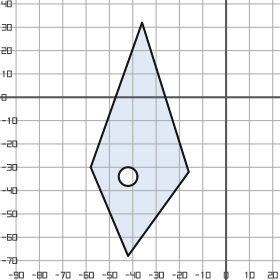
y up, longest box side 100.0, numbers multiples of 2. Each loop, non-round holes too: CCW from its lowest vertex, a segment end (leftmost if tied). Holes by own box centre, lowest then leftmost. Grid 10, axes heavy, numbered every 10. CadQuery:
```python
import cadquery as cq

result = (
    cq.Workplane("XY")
    .moveTo(-42.0, -68.0)
    .lineTo(-16.0, -32.0)
    .lineTo(-36.0, 32.0)
    .lineTo(-58.0, -30.0)
    .close()
    .moveTo(-42.0, -34.0)
    .circle(4.0)
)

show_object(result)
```